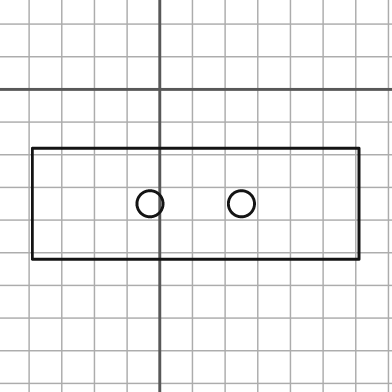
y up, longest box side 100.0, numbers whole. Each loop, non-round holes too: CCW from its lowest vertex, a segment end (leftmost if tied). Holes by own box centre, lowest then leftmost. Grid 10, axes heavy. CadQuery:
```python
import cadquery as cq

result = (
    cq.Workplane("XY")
    .moveTo(-39.0, -52.0)
    .lineTo(61.0, -52.0)
    .lineTo(61.0, -18.0)
    .lineTo(-39.0, -18.0)
    .close()
    .moveTo(-3.0, -35.0)
    .circle(4.0)
    .moveTo(25.0, -35.0)
    .circle(4.0)
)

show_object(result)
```